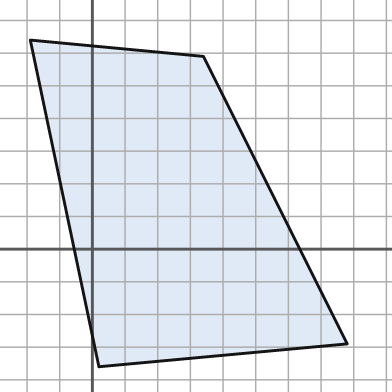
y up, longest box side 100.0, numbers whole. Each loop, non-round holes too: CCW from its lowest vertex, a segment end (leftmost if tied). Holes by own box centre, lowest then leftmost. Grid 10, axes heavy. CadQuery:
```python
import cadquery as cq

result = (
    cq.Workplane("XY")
    .moveTo(2.0, -36.0)
    .lineTo(78.0, -29.0)
    .lineTo(34.0, 59.0)
    .lineTo(-19.0, 64.0)
    .close()
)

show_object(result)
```